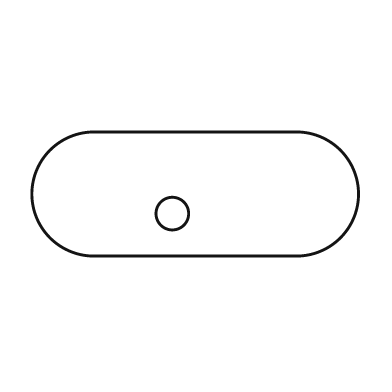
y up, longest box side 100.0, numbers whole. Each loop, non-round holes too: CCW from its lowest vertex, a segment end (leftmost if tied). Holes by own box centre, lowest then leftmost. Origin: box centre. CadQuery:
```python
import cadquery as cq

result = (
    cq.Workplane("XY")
    .moveTo(-31.0, -19.0)
    .lineTo(31.0, -19.0)
    .threePointArc((50.0, 0.0), (31.0, 19.0))
    .lineTo(-31.0, 19.0)
    .threePointArc((-50.0, 0.0), (-31.0, -19.0))
    .close()
    .moveTo(-7.0, -6.0)
    .circle(5.0)
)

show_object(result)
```